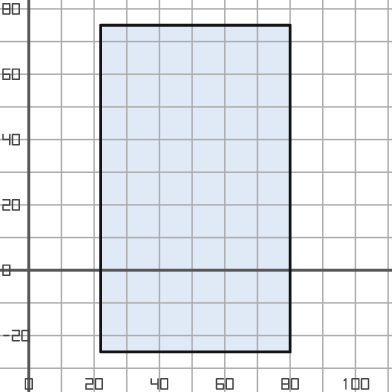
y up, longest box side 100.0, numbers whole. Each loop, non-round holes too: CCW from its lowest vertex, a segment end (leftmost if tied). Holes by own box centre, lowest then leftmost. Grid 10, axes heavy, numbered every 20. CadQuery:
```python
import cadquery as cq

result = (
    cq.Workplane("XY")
    .moveTo(22.0, -25.0)
    .lineTo(80.0, -25.0)
    .lineTo(80.0, 75.0)
    .lineTo(22.0, 75.0)
    .close()
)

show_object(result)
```